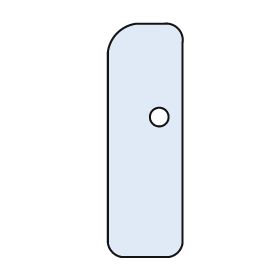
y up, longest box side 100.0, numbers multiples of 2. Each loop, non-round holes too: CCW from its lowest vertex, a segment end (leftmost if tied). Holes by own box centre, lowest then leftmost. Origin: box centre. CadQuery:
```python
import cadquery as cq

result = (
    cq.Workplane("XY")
    .moveTo(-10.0, -50.0)
    .lineTo(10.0, -50.0)
    .threePointArc((14.0, -48.0), (16.0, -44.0))
    .lineTo(16.0, 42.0)
    .threePointArc((14.0, 48.0), (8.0, 50.0))
    .lineTo(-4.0, 50.0)
    .threePointArc((-12.0, 46.0), (-16.0, 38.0))
    .lineTo(-16.0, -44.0)
    .threePointArc((-14.0, -48.0), (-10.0, -50.0))
    .close()
    .moveTo(6.0, 10.0)
    .circle(4.0)
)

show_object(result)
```